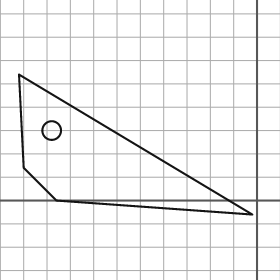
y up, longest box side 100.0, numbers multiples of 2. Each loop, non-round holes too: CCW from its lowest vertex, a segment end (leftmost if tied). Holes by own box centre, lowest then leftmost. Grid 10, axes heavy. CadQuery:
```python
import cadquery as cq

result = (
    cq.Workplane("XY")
    .moveTo(-2.0, -6.0)
    .lineTo(-102.0, 54.0)
    .lineTo(-100.0, 14.0)
    .lineTo(-86.0, 0.0)
    .close()
    .moveTo(-88.0, 30.0)
    .circle(4.0)
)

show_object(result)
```